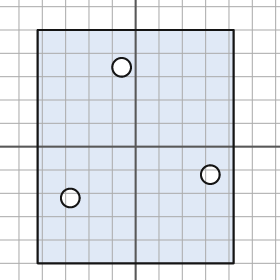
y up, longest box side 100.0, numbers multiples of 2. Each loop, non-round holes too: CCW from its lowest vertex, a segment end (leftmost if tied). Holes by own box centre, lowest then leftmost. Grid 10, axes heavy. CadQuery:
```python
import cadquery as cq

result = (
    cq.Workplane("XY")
    .moveTo(-42.0, -50.0)
    .lineTo(42.0, -50.0)
    .lineTo(42.0, 50.0)
    .lineTo(-42.0, 50.0)
    .close()
    .moveTo(-28.0, -22.0)
    .circle(4.0)
    .moveTo(32.0, -12.0)
    .circle(4.0)
    .moveTo(-6.0, 34.0)
    .circle(4.0)
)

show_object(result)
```